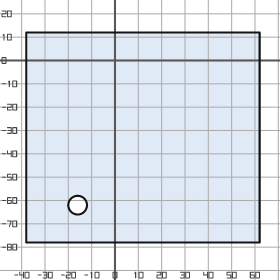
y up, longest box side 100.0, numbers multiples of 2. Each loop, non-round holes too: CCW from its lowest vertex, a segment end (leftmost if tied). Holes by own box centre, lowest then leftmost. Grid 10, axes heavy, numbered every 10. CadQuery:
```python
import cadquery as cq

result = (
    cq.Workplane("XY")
    .moveTo(-38.0, -78.0)
    .lineTo(62.0, -78.0)
    .lineTo(62.0, 12.0)
    .lineTo(-38.0, 12.0)
    .close()
    .moveTo(-16.0, -62.0)
    .circle(4.0)
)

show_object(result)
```